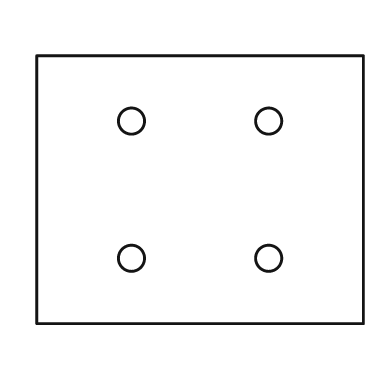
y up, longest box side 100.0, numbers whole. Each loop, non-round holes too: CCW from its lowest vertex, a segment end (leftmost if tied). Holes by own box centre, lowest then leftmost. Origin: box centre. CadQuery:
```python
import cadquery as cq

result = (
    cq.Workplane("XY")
    .moveTo(-50.0, -41.0)
    .lineTo(50.0, -41.0)
    .lineTo(50.0, 41.0)
    .lineTo(-50.0, 41.0)
    .close()
    .moveTo(-21.0, -21.0)
    .circle(4.0)
    .moveTo(21.0, -21.0)
    .circle(4.0)
    .moveTo(-21.0, 21.0)
    .circle(4.0)
    .moveTo(21.0, 21.0)
    .circle(4.0)
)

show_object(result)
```